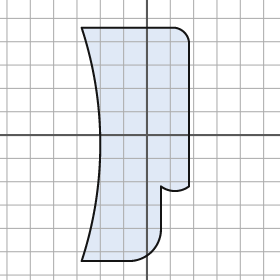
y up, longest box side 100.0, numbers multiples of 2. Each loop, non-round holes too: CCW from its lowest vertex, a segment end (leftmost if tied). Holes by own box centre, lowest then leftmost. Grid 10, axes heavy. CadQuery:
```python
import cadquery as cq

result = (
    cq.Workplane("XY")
    .moveTo(-28.0, -54.0)
    .lineTo(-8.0, -54.0)
    .threePointArc((2.0, -50.0), (6.0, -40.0))
    .lineTo(6.0, -22.0)
    .threePointArc((12.0, -24.0), (18.0, -22.0))
    .lineTo(18.0, 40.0)
    .threePointArc((16.0, 44.0), (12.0, 46.0))
    .lineTo(-28.0, 46.0)
    .threePointArc((-20.0, -4.0), (-28.0, -54.0))
    .close()
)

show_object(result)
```